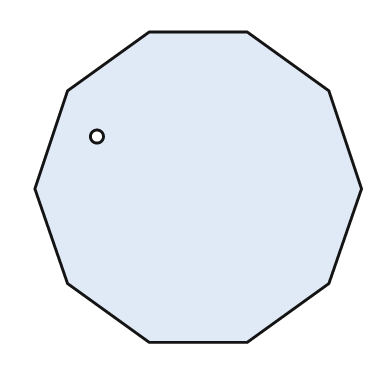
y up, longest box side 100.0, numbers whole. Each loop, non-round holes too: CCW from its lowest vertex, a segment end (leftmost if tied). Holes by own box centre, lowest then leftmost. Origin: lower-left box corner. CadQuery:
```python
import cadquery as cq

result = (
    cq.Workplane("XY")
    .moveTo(35.0, 0.0)
    .lineTo(65.0, 0.0)
    .lineTo(90.0, 18.0)
    .lineTo(100.0, 47.0)
    .lineTo(90.0, 77.0)
    .lineTo(65.0, 95.0)
    .lineTo(35.0, 95.0)
    .lineTo(10.0, 77.0)
    .lineTo(0.0, 47.0)
    .lineTo(10.0, 18.0)
    .close()
    .moveTo(19.0, 63.0)
    .circle(2.0)
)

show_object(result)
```